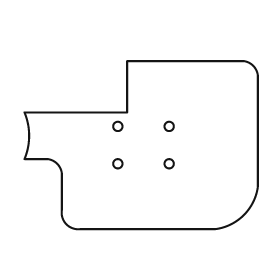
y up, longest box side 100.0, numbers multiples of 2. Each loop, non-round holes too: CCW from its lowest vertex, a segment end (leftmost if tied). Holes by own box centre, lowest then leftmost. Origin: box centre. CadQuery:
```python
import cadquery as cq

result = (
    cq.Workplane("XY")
    .moveTo(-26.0, -36.0)
    .lineTo(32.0, -36.0)
    .threePointArc((44.0, -30.0), (50.0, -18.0))
    .lineTo(50.0, 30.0)
    .threePointArc((48.0, 34.0), (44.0, 36.0))
    .lineTo(-6.0, 36.0)
    .lineTo(-6.0, 14.0)
    .lineTo(-50.0, 14.0)
    .threePointArc((-48.0, 4.0), (-50.0, -6.0))
    .lineTo(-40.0, -6.0)
    .threePointArc((-36.0, -8.0), (-34.0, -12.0))
    .lineTo(-34.0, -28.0)
    .threePointArc((-32.0, -34.0), (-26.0, -36.0))
    .close()
    .moveTo(-10.0, -8.0)
    .circle(2.0)
    .moveTo(12.0, -8.0)
    .circle(2.0)
    .moveTo(-10.0, 8.0)
    .circle(2.0)
    .moveTo(12.0, 8.0)
    .circle(2.0)
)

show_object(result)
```